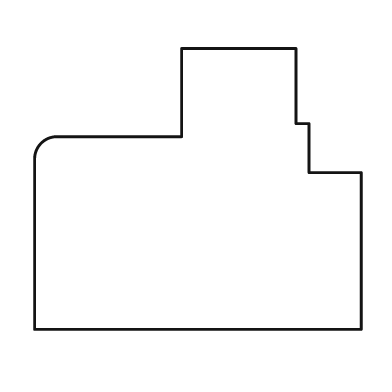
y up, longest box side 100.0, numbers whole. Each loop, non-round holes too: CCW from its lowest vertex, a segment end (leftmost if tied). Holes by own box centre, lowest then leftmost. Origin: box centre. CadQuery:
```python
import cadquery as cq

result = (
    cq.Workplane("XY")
    .moveTo(-50.0, -43.0)
    .lineTo(50.0, -43.0)
    .lineTo(50.0, 5.0)
    .lineTo(34.0, 5.0)
    .lineTo(34.0, 20.0)
    .lineTo(30.0, 20.0)
    .lineTo(30.0, 43.0)
    .lineTo(-5.0, 43.0)
    .lineTo(-5.0, 16.0)
    .lineTo(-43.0, 16.0)
    .threePointArc((-48.0, 14.0), (-50.0, 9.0))
    .close()
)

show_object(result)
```